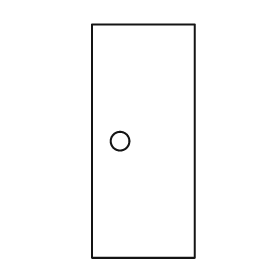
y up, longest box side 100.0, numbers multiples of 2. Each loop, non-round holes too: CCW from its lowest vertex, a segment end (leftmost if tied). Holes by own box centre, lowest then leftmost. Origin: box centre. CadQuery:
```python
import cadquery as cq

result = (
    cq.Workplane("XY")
    .moveTo(-22.0, -50.0)
    .lineTo(22.0, -50.0)
    .lineTo(22.0, 50.0)
    .lineTo(-22.0, 50.0)
    .close()
    .moveTo(-10.0, 0.0)
    .circle(4.0)
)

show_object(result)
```